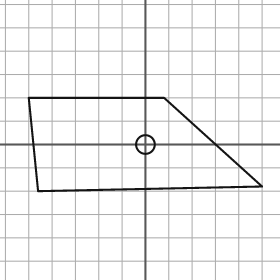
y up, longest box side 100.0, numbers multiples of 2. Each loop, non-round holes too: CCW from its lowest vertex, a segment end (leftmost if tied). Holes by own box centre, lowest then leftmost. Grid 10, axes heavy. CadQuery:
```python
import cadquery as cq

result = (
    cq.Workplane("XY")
    .moveTo(-46.0, -20.0)
    .lineTo(50.0, -18.0)
    .lineTo(8.0, 20.0)
    .lineTo(-50.0, 20.0)
    .close()
    .moveTo(0.0, 0.0)
    .circle(4.0)
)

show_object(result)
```